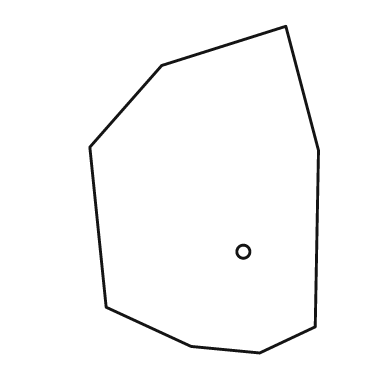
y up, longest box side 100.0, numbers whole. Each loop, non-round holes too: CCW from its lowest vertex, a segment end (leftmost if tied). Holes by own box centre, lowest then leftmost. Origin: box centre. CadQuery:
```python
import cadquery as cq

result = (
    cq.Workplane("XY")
    .moveTo(17.0, -50.0)
    .lineTo(34.0, -42.0)
    .lineTo(35.0, 12.0)
    .lineTo(25.0, 50.0)
    .lineTo(-13.0, 38.0)
    .lineTo(-35.0, 13.0)
    .lineTo(-30.0, -36.0)
    .lineTo(-4.0, -48.0)
    .close()
    .moveTo(12.0, -19.0)
    .circle(2.0)
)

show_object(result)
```